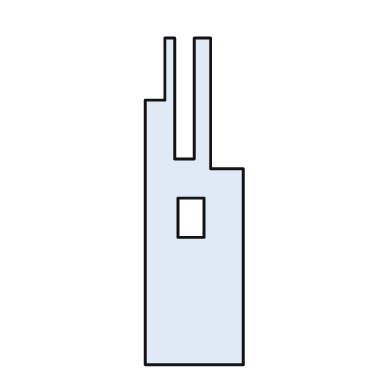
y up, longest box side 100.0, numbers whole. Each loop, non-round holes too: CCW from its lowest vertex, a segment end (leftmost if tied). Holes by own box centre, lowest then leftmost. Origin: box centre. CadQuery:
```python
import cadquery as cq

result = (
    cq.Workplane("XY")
    .moveTo(-15.0, -50.0)
    .lineTo(15.0, -50.0)
    .lineTo(15.0, 10.0)
    .lineTo(5.0, 10.0)
    .lineTo(5.0, 50.0)
    .lineTo(0.0, 50.0)
    .lineTo(0.0, 13.0)
    .lineTo(-6.0, 13.0)
    .lineTo(-6.0, 50.0)
    .lineTo(-9.0, 50.0)
    .lineTo(-9.0, 31.0)
    .lineTo(-15.0, 31.0)
    .close()
    .moveTo(-5.0, -11.0)
    .lineTo(3.0, -11.0)
    .lineTo(3.0, 1.0)
    .lineTo(-5.0, 1.0)
    .close()
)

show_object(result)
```